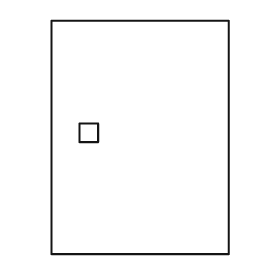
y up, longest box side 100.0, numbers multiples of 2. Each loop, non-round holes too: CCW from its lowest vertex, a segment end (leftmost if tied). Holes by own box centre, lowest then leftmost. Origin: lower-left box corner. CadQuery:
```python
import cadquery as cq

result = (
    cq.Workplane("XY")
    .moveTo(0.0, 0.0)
    .lineTo(76.0, 0.0)
    .lineTo(76.0, 100.0)
    .lineTo(0.0, 100.0)
    .close()
    .moveTo(12.0, 48.0)
    .lineTo(20.0, 48.0)
    .lineTo(20.0, 56.0)
    .lineTo(12.0, 56.0)
    .close()
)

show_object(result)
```